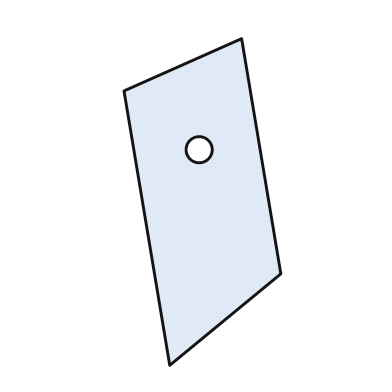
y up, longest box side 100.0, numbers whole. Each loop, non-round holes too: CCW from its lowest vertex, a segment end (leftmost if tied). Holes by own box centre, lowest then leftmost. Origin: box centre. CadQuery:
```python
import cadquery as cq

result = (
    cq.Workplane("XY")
    .moveTo(-10.0, -50.0)
    .lineTo(24.0, -22.0)
    .lineTo(12.0, 50.0)
    .lineTo(-24.0, 34.0)
    .close()
    .moveTo(-1.0, 16.0)
    .circle(4.0)
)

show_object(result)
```